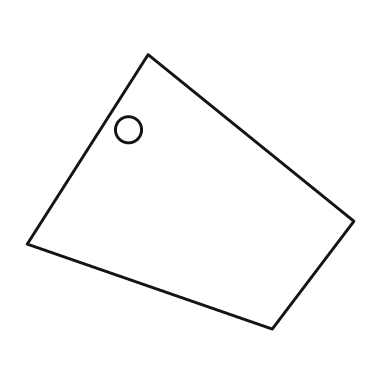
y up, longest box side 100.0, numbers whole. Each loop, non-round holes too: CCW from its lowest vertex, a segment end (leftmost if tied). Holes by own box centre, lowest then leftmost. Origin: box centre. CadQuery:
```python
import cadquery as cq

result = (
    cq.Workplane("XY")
    .moveTo(25.0, -42.0)
    .lineTo(50.0, -9.0)
    .lineTo(-13.0, 42.0)
    .lineTo(-50.0, -16.0)
    .close()
    .moveTo(-19.0, 19.0)
    .circle(4.0)
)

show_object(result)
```